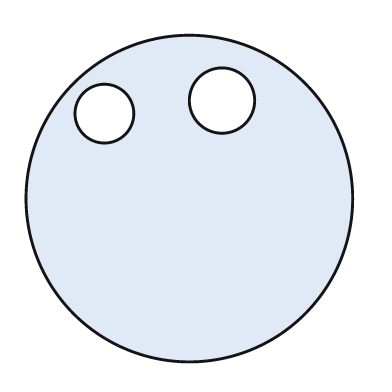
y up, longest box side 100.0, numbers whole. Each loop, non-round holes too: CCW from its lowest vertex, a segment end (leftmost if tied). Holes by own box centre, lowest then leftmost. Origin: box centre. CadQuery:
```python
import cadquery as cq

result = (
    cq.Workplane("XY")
    .moveTo(0.0, 0.0)
    .circle(50.0)
    .moveTo(-26.0, 26.0)
    .circle(9.0)
    .moveTo(10.0, 30.0)
    .circle(10.0)
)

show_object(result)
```